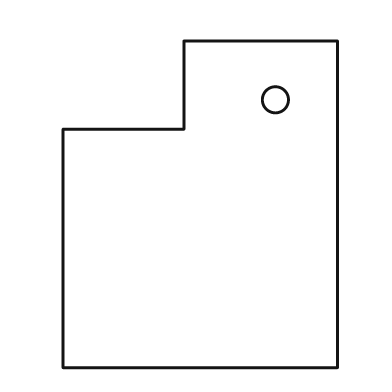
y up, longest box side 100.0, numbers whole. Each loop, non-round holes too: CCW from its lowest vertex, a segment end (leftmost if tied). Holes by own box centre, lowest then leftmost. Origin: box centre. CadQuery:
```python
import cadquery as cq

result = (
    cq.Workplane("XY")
    .moveTo(-42.0, -50.0)
    .lineTo(42.0, -50.0)
    .lineTo(42.0, 50.0)
    .lineTo(-5.0, 50.0)
    .lineTo(-5.0, 23.0)
    .lineTo(-42.0, 23.0)
    .close()
    .moveTo(23.0, 32.0)
    .circle(4.0)
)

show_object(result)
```